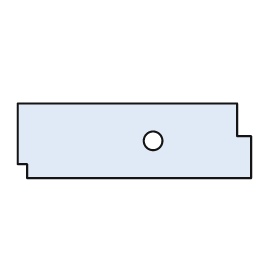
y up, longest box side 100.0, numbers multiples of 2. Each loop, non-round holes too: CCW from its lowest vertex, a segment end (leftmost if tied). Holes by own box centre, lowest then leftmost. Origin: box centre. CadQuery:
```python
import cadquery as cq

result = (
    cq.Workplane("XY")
    .moveTo(-46.0, -16.0)
    .lineTo(50.0, -16.0)
    .lineTo(50.0, 2.0)
    .lineTo(44.0, 2.0)
    .lineTo(44.0, 16.0)
    .lineTo(-50.0, 16.0)
    .lineTo(-50.0, -10.0)
    .lineTo(-46.0, -10.0)
    .close()
    .moveTo(8.0, 0.0)
    .circle(4.0)
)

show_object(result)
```